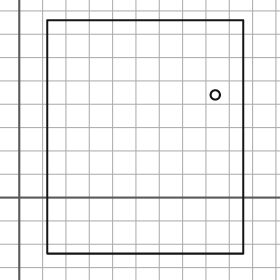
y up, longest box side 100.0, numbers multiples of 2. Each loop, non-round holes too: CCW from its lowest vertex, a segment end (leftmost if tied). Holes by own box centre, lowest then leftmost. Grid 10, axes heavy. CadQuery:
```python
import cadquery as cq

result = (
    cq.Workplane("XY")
    .moveTo(12.0, -24.0)
    .lineTo(96.0, -24.0)
    .lineTo(96.0, 76.0)
    .lineTo(12.0, 76.0)
    .close()
    .moveTo(84.0, 44.0)
    .circle(2.0)
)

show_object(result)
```